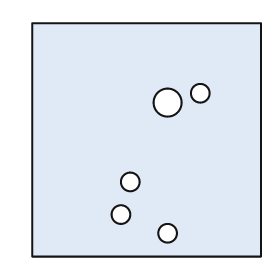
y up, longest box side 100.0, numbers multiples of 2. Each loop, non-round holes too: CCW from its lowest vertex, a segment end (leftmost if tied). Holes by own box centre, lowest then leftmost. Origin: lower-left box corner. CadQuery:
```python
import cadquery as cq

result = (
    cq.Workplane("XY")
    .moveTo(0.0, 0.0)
    .lineTo(98.0, 0.0)
    .lineTo(98.0, 100.0)
    .lineTo(0.0, 100.0)
    .close()
    .moveTo(58.0, 10.0)
    .circle(4.0)
    .moveTo(38.0, 18.0)
    .circle(4.0)
    .moveTo(42.0, 32.0)
    .circle(4.0)
    .moveTo(58.0, 66.0)
    .circle(6.0)
    .moveTo(72.0, 70.0)
    .circle(4.0)
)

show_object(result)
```